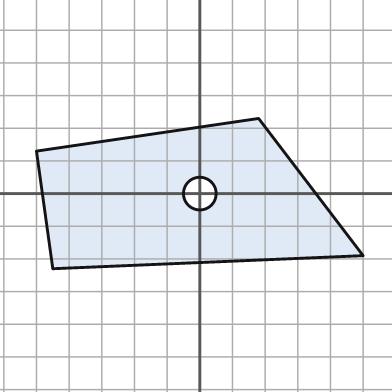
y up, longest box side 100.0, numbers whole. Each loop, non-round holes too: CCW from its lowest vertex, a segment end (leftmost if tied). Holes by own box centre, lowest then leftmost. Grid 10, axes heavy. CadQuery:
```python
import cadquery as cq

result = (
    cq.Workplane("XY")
    .moveTo(-45.0, -23.0)
    .lineTo(50.0, -19.0)
    .lineTo(18.0, 23.0)
    .lineTo(-50.0, 13.0)
    .close()
    .moveTo(0.0, 0.0)
    .circle(5.0)
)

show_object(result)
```